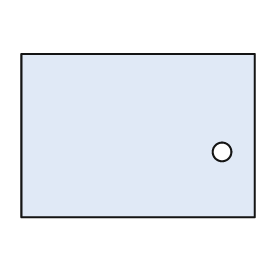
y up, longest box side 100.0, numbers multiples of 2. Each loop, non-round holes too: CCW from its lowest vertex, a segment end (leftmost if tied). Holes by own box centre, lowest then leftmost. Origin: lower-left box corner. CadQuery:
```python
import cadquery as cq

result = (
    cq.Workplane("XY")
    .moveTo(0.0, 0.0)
    .lineTo(100.0, 0.0)
    .lineTo(100.0, 70.0)
    .lineTo(0.0, 70.0)
    .close()
    .moveTo(86.0, 28.0)
    .circle(4.0)
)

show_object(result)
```